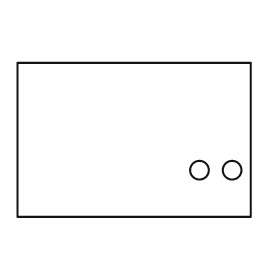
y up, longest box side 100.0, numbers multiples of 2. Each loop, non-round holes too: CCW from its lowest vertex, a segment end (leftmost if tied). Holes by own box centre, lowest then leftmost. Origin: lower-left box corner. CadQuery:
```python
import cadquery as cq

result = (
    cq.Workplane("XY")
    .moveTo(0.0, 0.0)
    .lineTo(100.0, 0.0)
    .lineTo(100.0, 66.0)
    .lineTo(0.0, 66.0)
    .close()
    .moveTo(78.0, 20.0)
    .circle(4.0)
    .moveTo(92.0, 20.0)
    .circle(4.0)
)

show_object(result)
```